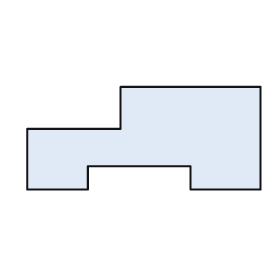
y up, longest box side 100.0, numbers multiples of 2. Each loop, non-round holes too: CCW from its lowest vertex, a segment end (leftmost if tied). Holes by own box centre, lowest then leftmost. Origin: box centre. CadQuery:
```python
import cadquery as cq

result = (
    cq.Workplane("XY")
    .moveTo(-50.0, -22.0)
    .lineTo(-24.0, -22.0)
    .lineTo(-24.0, -12.0)
    .lineTo(20.0, -12.0)
    .lineTo(20.0, -22.0)
    .lineTo(50.0, -22.0)
    .lineTo(50.0, 22.0)
    .lineTo(-10.0, 22.0)
    .lineTo(-10.0, 4.0)
    .lineTo(-50.0, 4.0)
    .close()
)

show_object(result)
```